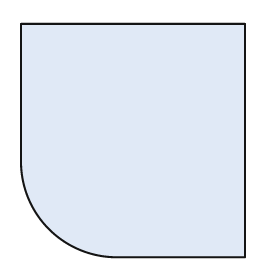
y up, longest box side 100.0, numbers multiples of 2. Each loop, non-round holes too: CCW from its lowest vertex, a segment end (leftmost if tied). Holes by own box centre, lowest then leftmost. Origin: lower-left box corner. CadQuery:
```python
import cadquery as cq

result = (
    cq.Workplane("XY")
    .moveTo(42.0, 0.0)
    .lineTo(96.0, 0.0)
    .lineTo(96.0, 100.0)
    .lineTo(0.0, 100.0)
    .lineTo(0.0, 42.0)
    .threePointArc((12.0, 12.0), (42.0, 0.0))
    .close()
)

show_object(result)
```